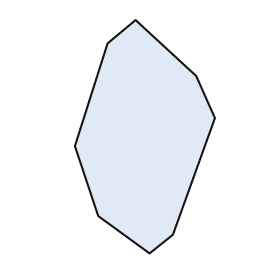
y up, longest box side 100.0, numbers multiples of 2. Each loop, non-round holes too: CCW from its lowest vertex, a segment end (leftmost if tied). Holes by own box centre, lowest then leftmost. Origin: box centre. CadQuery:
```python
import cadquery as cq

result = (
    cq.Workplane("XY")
    .moveTo(2.0, -50.0)
    .lineTo(12.0, -42.0)
    .lineTo(30.0, 8.0)
    .lineTo(22.0, 26.0)
    .lineTo(-4.0, 50.0)
    .lineTo(-16.0, 40.0)
    .lineTo(-30.0, -4.0)
    .lineTo(-20.0, -34.0)
    .close()
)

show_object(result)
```